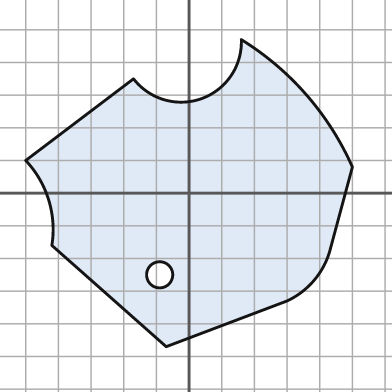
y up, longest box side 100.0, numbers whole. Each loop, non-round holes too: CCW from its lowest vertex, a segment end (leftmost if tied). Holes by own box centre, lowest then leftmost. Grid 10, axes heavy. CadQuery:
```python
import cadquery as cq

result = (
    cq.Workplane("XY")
    .moveTo(-7.0, -47.0)
    .lineTo(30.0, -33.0)
    .threePointArc((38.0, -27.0), (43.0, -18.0))
    .lineTo(50.0, 8.0)
    .threePointArc((36.0, 30.0), (16.0, 47.0))
    .threePointArc((4.0, 29.0), (-17.0, 35.0))
    .lineTo(-50.0, 10.0)
    .threePointArc((-43.0, -2.0), (-42.0, -16.0))
    .close()
    .moveTo(-9.0, -25.0)
    .circle(4.0)
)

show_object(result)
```